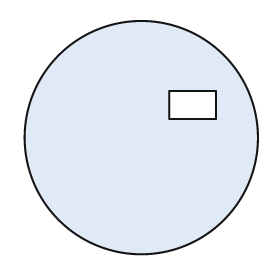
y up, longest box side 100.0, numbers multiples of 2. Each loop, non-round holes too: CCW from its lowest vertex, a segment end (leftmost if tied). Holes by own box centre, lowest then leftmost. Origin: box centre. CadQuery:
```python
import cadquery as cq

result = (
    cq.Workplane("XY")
    .moveTo(0.0, 0.0)
    .circle(50.0)
    .moveTo(12.0, 8.0)
    .lineTo(32.0, 8.0)
    .lineTo(32.0, 20.0)
    .lineTo(12.0, 20.0)
    .close()
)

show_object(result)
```